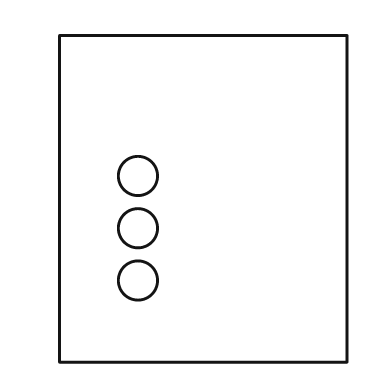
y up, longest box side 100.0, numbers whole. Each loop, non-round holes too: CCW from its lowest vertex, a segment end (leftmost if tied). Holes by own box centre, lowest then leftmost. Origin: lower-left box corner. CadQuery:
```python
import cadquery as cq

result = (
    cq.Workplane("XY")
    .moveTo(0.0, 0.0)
    .lineTo(88.0, 0.0)
    .lineTo(88.0, 100.0)
    .lineTo(0.0, 100.0)
    .close()
    .moveTo(24.0, 25.0)
    .circle(6.0)
    .moveTo(24.0, 41.0)
    .circle(6.0)
    .moveTo(24.0, 57.0)
    .circle(6.0)
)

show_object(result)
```